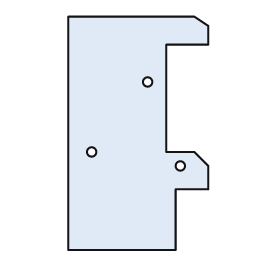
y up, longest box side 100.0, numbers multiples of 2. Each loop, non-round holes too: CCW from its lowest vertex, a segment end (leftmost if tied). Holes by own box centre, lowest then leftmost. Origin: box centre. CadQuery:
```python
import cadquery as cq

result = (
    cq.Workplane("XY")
    .moveTo(-30.0, -50.0)
    .lineTo(16.0, -50.0)
    .lineTo(16.0, -24.0)
    .lineTo(30.0, -24.0)
    .lineTo(30.0, -14.0)
    .lineTo(24.0, -8.0)
    .lineTo(12.0, -8.0)
    .lineTo(12.0, 38.0)
    .lineTo(30.0, 38.0)
    .lineTo(30.0, 46.0)
    .lineTo(24.0, 50.0)
    .lineTo(-30.0, 50.0)
    .close()
    .moveTo(18.0, -14.0)
    .circle(2.0)
    .moveTo(-20.0, -8.0)
    .circle(2.0)
    .moveTo(4.0, 22.0)
    .circle(2.0)
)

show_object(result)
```